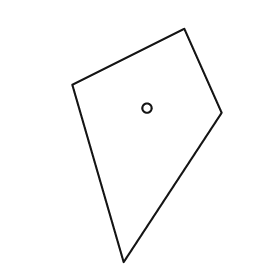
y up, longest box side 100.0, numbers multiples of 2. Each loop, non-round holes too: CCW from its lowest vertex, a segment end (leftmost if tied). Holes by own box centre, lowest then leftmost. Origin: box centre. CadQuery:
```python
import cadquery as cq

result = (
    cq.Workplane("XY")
    .moveTo(-10.0, -50.0)
    .lineTo(32.0, 14.0)
    .lineTo(16.0, 50.0)
    .lineTo(-32.0, 26.0)
    .close()
    .moveTo(0.0, 16.0)
    .circle(2.0)
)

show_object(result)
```